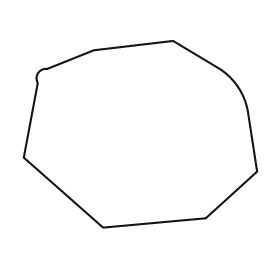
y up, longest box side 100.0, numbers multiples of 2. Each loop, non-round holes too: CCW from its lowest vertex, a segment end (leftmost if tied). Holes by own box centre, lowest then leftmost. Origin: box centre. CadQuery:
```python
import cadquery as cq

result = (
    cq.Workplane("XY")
    .moveTo(-16.0, -40.0)
    .lineTo(28.0, -36.0)
    .lineTo(50.0, -16.0)
    .lineTo(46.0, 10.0)
    .threePointArc((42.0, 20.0), (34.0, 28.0))
    .lineTo(14.0, 40.0)
    .lineTo(-20.0, 36.0)
    .lineTo(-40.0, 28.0)
    .threePointArc((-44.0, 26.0), (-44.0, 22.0))
    .lineTo(-50.0, -10.0)
    .close()
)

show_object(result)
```